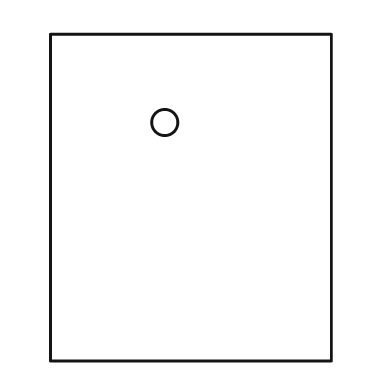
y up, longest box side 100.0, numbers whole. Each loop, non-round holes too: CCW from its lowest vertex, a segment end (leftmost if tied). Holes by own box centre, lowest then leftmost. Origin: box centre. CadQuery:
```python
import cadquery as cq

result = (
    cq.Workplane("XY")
    .moveTo(-43.0, -50.0)
    .lineTo(43.0, -50.0)
    .lineTo(43.0, 50.0)
    .lineTo(-43.0, 50.0)
    .close()
    .moveTo(-8.0, 23.0)
    .circle(4.0)
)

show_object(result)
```